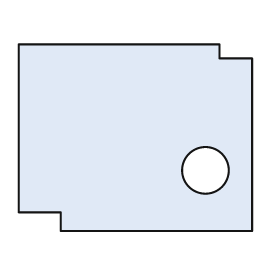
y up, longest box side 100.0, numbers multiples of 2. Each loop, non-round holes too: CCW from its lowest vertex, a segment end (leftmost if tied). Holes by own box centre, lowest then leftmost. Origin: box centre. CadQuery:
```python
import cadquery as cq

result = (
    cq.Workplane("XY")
    .moveTo(-32.0, -40.0)
    .lineTo(50.0, -40.0)
    .lineTo(50.0, 34.0)
    .lineTo(36.0, 34.0)
    .lineTo(36.0, 40.0)
    .lineTo(-50.0, 40.0)
    .lineTo(-50.0, -32.0)
    .lineTo(-32.0, -32.0)
    .close()
    .moveTo(30.0, -14.0)
    .circle(10.0)
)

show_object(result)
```